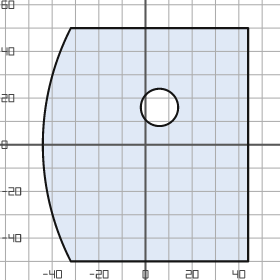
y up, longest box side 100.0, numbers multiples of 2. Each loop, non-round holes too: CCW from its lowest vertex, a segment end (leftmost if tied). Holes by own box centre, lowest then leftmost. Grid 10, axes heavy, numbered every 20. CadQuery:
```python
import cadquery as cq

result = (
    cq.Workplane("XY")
    .moveTo(-32.0, -50.0)
    .lineTo(44.0, -50.0)
    .lineTo(44.0, 50.0)
    .lineTo(-32.0, 50.0)
    .threePointArc((-44.0, 0.0), (-32.0, -50.0))
    .close()
    .moveTo(6.0, 16.0)
    .circle(8.0)
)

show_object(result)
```